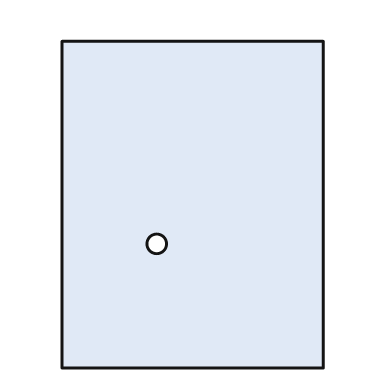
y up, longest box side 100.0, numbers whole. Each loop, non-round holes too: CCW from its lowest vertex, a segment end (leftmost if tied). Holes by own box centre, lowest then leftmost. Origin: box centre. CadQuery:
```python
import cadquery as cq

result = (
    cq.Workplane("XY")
    .moveTo(-40.0, -50.0)
    .lineTo(40.0, -50.0)
    .lineTo(40.0, 50.0)
    .lineTo(-40.0, 50.0)
    .close()
    .moveTo(-11.0, -12.0)
    .circle(3.0)
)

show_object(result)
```